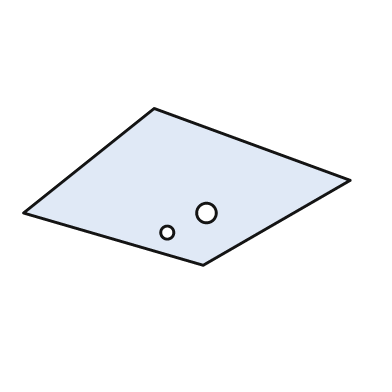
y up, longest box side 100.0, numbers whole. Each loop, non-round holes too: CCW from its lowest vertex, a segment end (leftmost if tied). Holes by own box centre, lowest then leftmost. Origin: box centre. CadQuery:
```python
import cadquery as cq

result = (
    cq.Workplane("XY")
    .moveTo(5.0, -24.0)
    .lineTo(50.0, 2.0)
    .lineTo(-10.0, 24.0)
    .lineTo(-50.0, -8.0)
    .close()
    .moveTo(-6.0, -14.0)
    .circle(2.0)
    .moveTo(6.0, -8.0)
    .circle(3.0)
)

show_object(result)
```